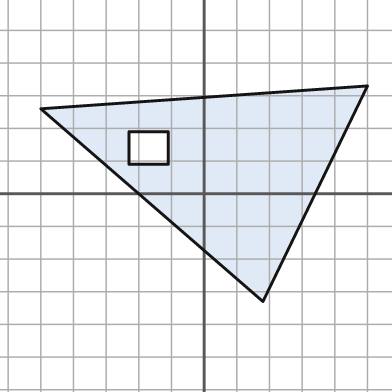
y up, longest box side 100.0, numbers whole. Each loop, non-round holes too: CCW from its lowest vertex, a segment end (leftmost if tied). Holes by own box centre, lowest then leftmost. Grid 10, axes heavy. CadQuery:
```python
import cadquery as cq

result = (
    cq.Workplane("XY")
    .moveTo(18.0, -33.0)
    .lineTo(50.0, 33.0)
    .lineTo(-50.0, 26.0)
    .close()
    .moveTo(-23.0, 9.0)
    .lineTo(-11.0, 9.0)
    .lineTo(-11.0, 19.0)
    .lineTo(-23.0, 19.0)
    .close()
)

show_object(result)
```